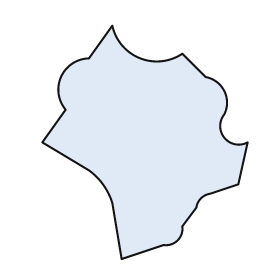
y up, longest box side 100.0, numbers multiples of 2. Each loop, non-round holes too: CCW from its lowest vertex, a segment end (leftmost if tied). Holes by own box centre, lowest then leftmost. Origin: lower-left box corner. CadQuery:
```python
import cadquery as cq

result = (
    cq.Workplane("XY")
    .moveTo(34.0, 0.0)
    .lineTo(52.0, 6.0)
    .threePointArc((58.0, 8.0), (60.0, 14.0))
    .lineTo(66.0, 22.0)
    .threePointArc((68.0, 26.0), (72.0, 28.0))
    .lineTo(84.0, 32.0)
    .lineTo(88.0, 50.0)
    .threePointArc((78.0, 52.0), (78.0, 62.0))
    .threePointArc((78.0, 72.0), (70.0, 78.0))
    .lineTo(60.0, 88.0)
    .threePointArc((42.0, 86.0), (30.0, 100.0))
    .lineTo(20.0, 86.0)
    .threePointArc((8.0, 78.0), (10.0, 64.0))
    .lineTo(0.0, 50.0)
    .lineTo(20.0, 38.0)
    .threePointArc((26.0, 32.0), (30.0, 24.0))
    .close()
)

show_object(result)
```